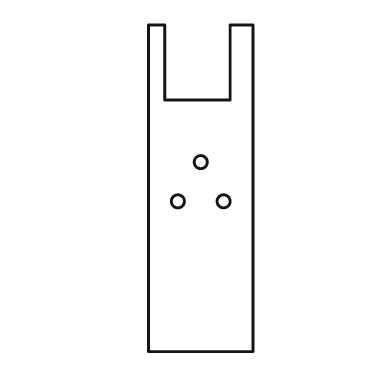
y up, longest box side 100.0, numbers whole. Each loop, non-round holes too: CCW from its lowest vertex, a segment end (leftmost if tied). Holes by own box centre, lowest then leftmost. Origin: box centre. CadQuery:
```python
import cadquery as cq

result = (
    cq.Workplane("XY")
    .moveTo(-16.0, -50.0)
    .lineTo(16.0, -50.0)
    .lineTo(16.0, 50.0)
    .lineTo(9.0, 50.0)
    .lineTo(9.0, 27.0)
    .lineTo(-11.0, 27.0)
    .lineTo(-11.0, 50.0)
    .lineTo(-16.0, 50.0)
    .close()
    .moveTo(-7.0, -4.0)
    .circle(2.0)
    .moveTo(7.0, -4.0)
    .circle(2.0)
    .moveTo(0.0, 8.0)
    .circle(2.0)
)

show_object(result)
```